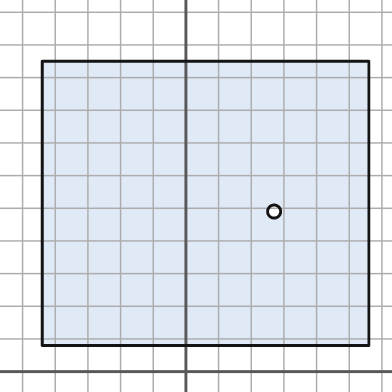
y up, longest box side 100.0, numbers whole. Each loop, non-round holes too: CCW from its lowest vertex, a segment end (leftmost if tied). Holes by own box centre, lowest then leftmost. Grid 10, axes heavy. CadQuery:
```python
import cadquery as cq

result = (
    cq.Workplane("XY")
    .moveTo(-44.0, 8.0)
    .lineTo(56.0, 8.0)
    .lineTo(56.0, 95.0)
    .lineTo(-44.0, 95.0)
    .close()
    .moveTo(27.0, 49.0)
    .circle(2.0)
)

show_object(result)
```